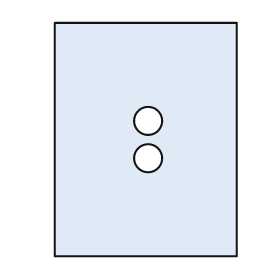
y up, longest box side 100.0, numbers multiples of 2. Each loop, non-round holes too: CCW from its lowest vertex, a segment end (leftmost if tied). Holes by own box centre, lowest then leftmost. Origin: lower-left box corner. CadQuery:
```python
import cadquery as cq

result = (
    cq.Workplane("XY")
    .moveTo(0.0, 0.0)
    .lineTo(78.0, 0.0)
    .lineTo(78.0, 100.0)
    .lineTo(0.0, 100.0)
    .close()
    .moveTo(40.0, 42.0)
    .circle(6.0)
    .moveTo(40.0, 58.0)
    .circle(6.0)
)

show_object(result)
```